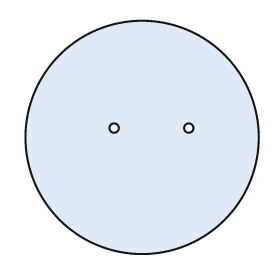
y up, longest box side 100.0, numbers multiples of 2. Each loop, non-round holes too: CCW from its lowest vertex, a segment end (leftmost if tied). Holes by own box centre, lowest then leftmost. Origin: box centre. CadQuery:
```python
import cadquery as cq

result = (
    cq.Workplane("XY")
    .moveTo(0.0, 0.0)
    .circle(50.0)
    .moveTo(-12.0, 4.0)
    .circle(2.0)
    .moveTo(20.0, 4.0)
    .circle(2.0)
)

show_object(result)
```